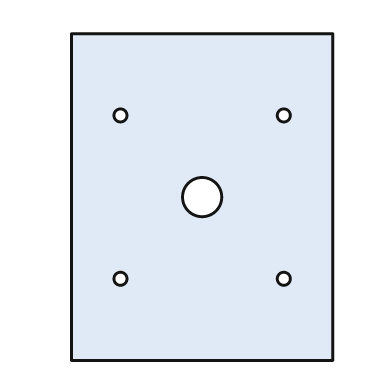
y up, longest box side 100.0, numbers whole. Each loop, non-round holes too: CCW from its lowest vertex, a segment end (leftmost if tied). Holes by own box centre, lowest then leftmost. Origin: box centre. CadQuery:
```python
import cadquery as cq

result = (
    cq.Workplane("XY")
    .moveTo(-40.0, -50.0)
    .lineTo(40.0, -50.0)
    .lineTo(40.0, 50.0)
    .lineTo(-40.0, 50.0)
    .close()
    .moveTo(-25.0, -25.0)
    .circle(2.0)
    .moveTo(25.0, -25.0)
    .circle(2.0)
    .moveTo(0.0, 0.0)
    .circle(6.0)
    .moveTo(-25.0, 25.0)
    .circle(2.0)
    .moveTo(25.0, 25.0)
    .circle(2.0)
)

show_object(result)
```